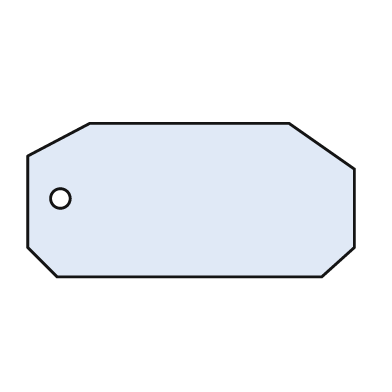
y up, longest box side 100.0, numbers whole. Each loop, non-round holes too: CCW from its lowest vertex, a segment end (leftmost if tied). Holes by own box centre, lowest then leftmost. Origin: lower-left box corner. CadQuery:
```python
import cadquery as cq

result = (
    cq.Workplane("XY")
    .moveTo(9.0, 0.0)
    .lineTo(90.0, 0.0)
    .lineTo(100.0, 9.0)
    .lineTo(100.0, 33.0)
    .lineTo(80.0, 47.0)
    .lineTo(19.0, 47.0)
    .lineTo(0.0, 37.0)
    .lineTo(0.0, 9.0)
    .close()
    .moveTo(10.0, 24.0)
    .circle(3.0)
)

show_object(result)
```